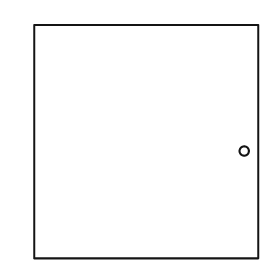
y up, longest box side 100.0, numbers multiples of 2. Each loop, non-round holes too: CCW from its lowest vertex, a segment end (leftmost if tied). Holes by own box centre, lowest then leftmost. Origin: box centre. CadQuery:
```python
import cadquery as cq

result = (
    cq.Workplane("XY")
    .moveTo(-48.0, -50.0)
    .lineTo(48.0, -50.0)
    .lineTo(48.0, 50.0)
    .lineTo(-48.0, 50.0)
    .close()
    .moveTo(42.0, -4.0)
    .circle(2.0)
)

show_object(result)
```